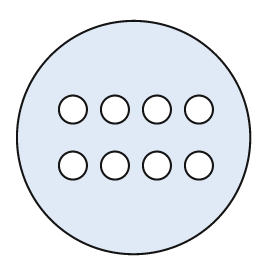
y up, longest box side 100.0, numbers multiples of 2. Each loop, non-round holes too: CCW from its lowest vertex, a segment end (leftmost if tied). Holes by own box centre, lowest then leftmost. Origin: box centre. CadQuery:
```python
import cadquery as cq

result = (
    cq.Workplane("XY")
    .moveTo(0.0, 0.0)
    .circle(50.0)
    .moveTo(-26.0, -12.0)
    .circle(6.0)
    .moveTo(-8.0, -12.0)
    .circle(6.0)
    .moveTo(10.0, -12.0)
    .circle(6.0)
    .moveTo(28.0, -12.0)
    .circle(6.0)
    .moveTo(-26.0, 12.0)
    .circle(6.0)
    .moveTo(-8.0, 12.0)
    .circle(6.0)
    .moveTo(10.0, 12.0)
    .circle(6.0)
    .moveTo(28.0, 12.0)
    .circle(6.0)
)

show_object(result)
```